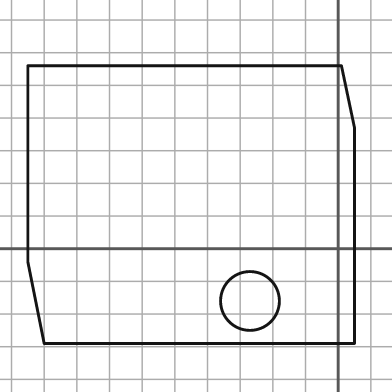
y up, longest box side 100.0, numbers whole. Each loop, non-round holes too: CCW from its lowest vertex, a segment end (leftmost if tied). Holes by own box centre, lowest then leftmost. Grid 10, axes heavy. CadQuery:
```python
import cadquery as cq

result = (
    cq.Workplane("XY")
    .moveTo(-90.0, -29.0)
    .lineTo(5.0, -29.0)
    .lineTo(5.0, 37.0)
    .lineTo(1.0, 56.0)
    .lineTo(-95.0, 56.0)
    .lineTo(-95.0, -4.0)
    .close()
    .moveTo(-27.0, -16.0)
    .circle(9.0)
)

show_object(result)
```